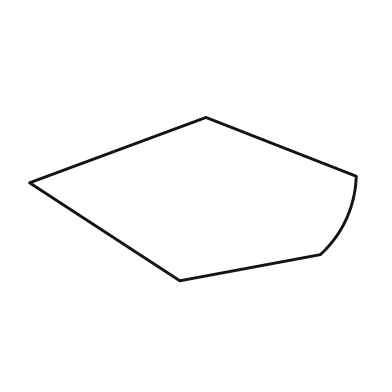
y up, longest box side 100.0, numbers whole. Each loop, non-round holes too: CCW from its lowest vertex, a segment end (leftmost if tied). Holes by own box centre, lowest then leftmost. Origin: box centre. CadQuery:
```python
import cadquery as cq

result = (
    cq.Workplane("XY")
    .moveTo(-4.0, -25.0)
    .lineTo(39.0, -17.0)
    .threePointArc((47.0, -6.0), (50.0, 7.0))
    .lineTo(4.0, 25.0)
    .lineTo(-50.0, 5.0)
    .close()
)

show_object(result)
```